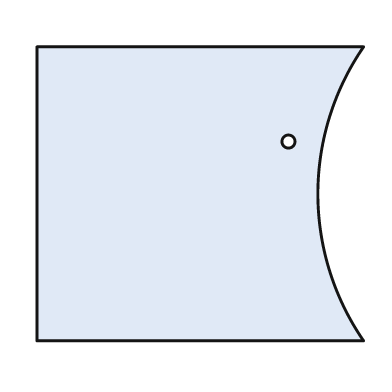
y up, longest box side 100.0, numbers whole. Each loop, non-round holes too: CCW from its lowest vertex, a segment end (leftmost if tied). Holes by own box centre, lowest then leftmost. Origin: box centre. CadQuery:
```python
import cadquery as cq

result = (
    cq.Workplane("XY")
    .moveTo(-50.0, -45.0)
    .lineTo(50.0, -45.0)
    .threePointArc((36.0, 0.0), (50.0, 45.0))
    .lineTo(-50.0, 45.0)
    .close()
    .moveTo(27.0, 16.0)
    .circle(2.0)
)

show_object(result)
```